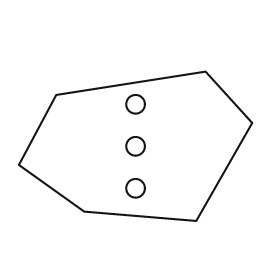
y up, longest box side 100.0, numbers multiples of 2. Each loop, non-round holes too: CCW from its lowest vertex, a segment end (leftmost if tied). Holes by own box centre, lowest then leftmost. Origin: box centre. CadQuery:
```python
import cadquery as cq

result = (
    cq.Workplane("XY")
    .moveTo(26.0, -32.0)
    .lineTo(50.0, 10.0)
    .lineTo(30.0, 32.0)
    .lineTo(-34.0, 22.0)
    .lineTo(-50.0, -8.0)
    .lineTo(-22.0, -28.0)
    .close()
    .moveTo(0.0, -18.0)
    .circle(4.0)
    .moveTo(0.0, 0.0)
    .circle(4.0)
    .moveTo(0.0, 18.0)
    .circle(4.0)
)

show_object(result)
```